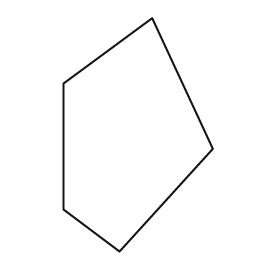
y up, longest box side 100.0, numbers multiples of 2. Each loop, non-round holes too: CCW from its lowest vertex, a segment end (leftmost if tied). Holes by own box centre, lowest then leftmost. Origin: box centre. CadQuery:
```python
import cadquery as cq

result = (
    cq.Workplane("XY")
    .moveTo(-8.0, -50.0)
    .lineTo(32.0, -6.0)
    .lineTo(6.0, 50.0)
    .lineTo(-32.0, 22.0)
    .lineTo(-32.0, -32.0)
    .close()
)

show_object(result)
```